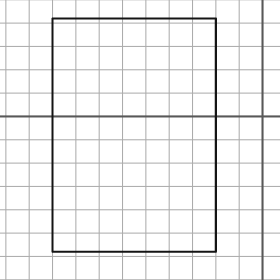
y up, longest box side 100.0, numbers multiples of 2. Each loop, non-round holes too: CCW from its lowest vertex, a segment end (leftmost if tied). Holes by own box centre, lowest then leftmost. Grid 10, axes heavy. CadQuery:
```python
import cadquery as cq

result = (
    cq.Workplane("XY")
    .moveTo(-90.0, -58.0)
    .lineTo(-20.0, -58.0)
    .lineTo(-20.0, 42.0)
    .lineTo(-90.0, 42.0)
    .close()
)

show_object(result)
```